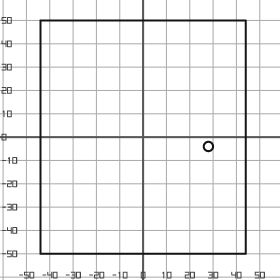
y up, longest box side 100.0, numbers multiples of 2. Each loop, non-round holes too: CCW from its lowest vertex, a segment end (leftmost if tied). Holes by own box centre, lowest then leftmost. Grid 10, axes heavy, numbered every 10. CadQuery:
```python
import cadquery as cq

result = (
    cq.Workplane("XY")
    .moveTo(-44.0, -50.0)
    .lineTo(44.0, -50.0)
    .lineTo(44.0, 50.0)
    .lineTo(-44.0, 50.0)
    .close()
    .moveTo(28.0, -4.0)
    .circle(2.0)
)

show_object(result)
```